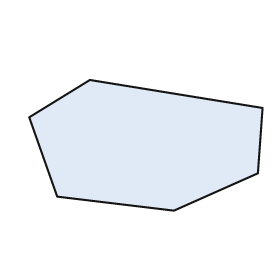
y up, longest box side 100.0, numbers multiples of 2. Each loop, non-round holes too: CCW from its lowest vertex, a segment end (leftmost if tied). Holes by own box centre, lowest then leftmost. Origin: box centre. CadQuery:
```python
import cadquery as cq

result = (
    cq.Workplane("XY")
    .moveTo(12.0, -28.0)
    .lineTo(48.0, -12.0)
    .lineTo(50.0, 16.0)
    .lineTo(-24.0, 28.0)
    .lineTo(-50.0, 12.0)
    .lineTo(-38.0, -22.0)
    .close()
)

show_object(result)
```